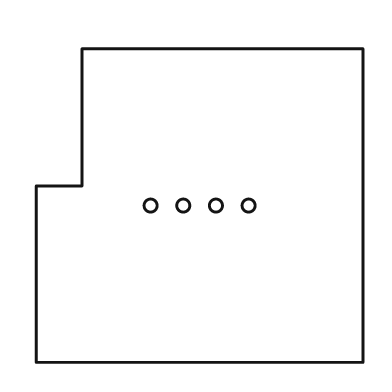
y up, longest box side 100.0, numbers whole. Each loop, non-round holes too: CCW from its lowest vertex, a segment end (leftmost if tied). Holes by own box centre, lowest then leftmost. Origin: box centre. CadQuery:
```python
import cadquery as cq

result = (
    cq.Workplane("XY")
    .moveTo(-50.0, -48.0)
    .lineTo(50.0, -48.0)
    .lineTo(50.0, 48.0)
    .lineTo(-36.0, 48.0)
    .lineTo(-36.0, 6.0)
    .lineTo(-50.0, 6.0)
    .close()
    .moveTo(-15.0, 0.0)
    .circle(2.0)
    .moveTo(-5.0, 0.0)
    .circle(2.0)
    .moveTo(5.0, 0.0)
    .circle(2.0)
    .moveTo(15.0, 0.0)
    .circle(2.0)
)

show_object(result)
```